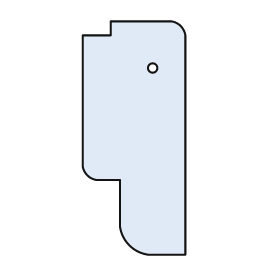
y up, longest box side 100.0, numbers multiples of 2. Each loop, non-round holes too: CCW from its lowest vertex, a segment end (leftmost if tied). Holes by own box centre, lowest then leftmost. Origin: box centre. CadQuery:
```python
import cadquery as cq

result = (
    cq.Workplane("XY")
    .moveTo(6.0, -50.0)
    .lineTo(22.0, -50.0)
    .lineTo(22.0, 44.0)
    .threePointArc((20.0, 48.0), (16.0, 50.0))
    .lineTo(-10.0, 50.0)
    .lineTo(-10.0, 44.0)
    .lineTo(-22.0, 44.0)
    .lineTo(-22.0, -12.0)
    .threePointArc((-20.0, -16.0), (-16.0, -18.0))
    .lineTo(-6.0, -18.0)
    .lineTo(-6.0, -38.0)
    .threePointArc((-2.0, -46.0), (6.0, -50.0))
    .close()
    .moveTo(8.0, 30.0)
    .circle(2.0)
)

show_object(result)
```